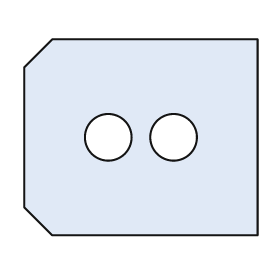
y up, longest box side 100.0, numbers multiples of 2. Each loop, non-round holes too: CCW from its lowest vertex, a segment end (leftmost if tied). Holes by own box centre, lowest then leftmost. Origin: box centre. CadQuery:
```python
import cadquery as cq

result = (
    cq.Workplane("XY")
    .moveTo(-38.0, -42.0)
    .lineTo(50.0, -42.0)
    .lineTo(50.0, 42.0)
    .lineTo(-38.0, 42.0)
    .lineTo(-50.0, 30.0)
    .lineTo(-50.0, -30.0)
    .close()
    .moveTo(-14.0, 0.0)
    .circle(10.0)
    .moveTo(14.0, 0.0)
    .circle(10.0)
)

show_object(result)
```